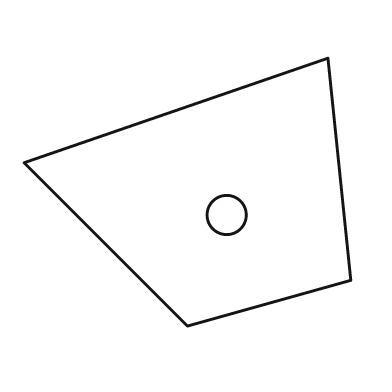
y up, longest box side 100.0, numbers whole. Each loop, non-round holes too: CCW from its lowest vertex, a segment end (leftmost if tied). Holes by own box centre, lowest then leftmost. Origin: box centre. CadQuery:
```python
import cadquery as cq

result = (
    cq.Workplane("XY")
    .moveTo(0.0, -41.0)
    .lineTo(50.0, -27.0)
    .lineTo(43.0, 41.0)
    .lineTo(-50.0, 9.0)
    .close()
    .moveTo(12.0, -7.0)
    .circle(6.0)
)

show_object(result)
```